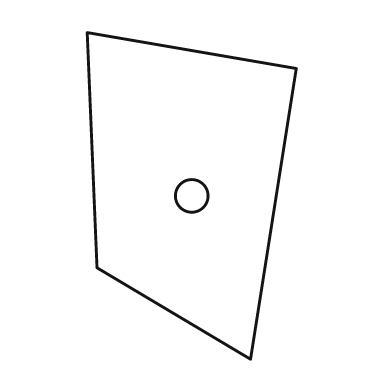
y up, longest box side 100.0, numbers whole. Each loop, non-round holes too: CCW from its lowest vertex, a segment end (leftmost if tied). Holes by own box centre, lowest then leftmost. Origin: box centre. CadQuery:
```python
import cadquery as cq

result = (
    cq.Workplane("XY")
    .moveTo(18.0, -50.0)
    .lineTo(32.0, 39.0)
    .lineTo(-32.0, 50.0)
    .lineTo(-29.0, -22.0)
    .close()
    .moveTo(0.0, 0.0)
    .circle(5.0)
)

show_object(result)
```